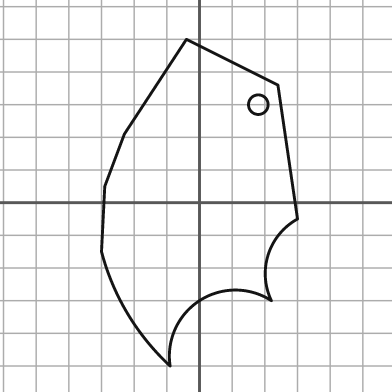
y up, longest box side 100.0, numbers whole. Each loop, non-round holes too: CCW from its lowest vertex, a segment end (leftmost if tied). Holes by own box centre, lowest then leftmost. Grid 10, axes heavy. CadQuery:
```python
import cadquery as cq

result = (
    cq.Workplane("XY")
    .moveTo(-9.0, -50.0)
    .threePointArc((0.0, -30.0), (22.0, -30.0))
    .threePointArc((21.0, -16.0), (30.0, -5.0))
    .lineTo(24.0, 36.0)
    .lineTo(-4.0, 50.0)
    .lineTo(-23.0, 21.0)
    .lineTo(-29.0, 5.0)
    .lineTo(-30.0, -15.0)
    .threePointArc((-22.0, -34.0), (-9.0, -50.0))
    .close()
    .moveTo(18.0, 30.0)
    .circle(3.0)
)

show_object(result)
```